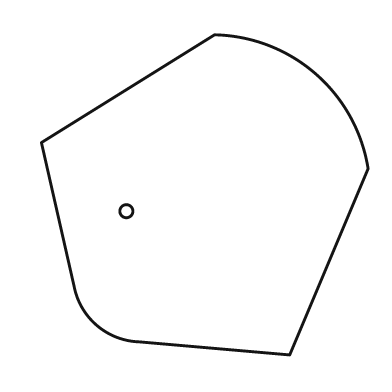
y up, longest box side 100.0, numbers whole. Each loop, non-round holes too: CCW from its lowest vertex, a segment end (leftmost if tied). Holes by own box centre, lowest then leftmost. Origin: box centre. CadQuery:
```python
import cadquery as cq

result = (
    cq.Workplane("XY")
    .moveTo(26.0, -49.0)
    .lineTo(50.0, 8.0)
    .threePointArc((34.0, 37.0), (3.0, 49.0))
    .lineTo(-50.0, 16.0)
    .lineTo(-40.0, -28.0)
    .threePointArc((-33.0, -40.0), (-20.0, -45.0))
    .close()
    .moveTo(-24.0, -5.0)
    .circle(2.0)
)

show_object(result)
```